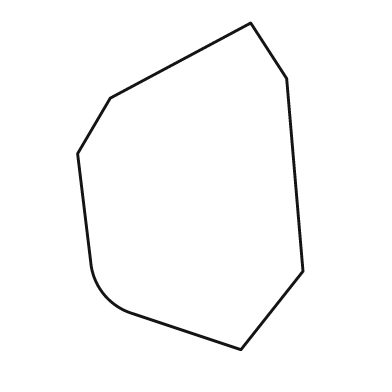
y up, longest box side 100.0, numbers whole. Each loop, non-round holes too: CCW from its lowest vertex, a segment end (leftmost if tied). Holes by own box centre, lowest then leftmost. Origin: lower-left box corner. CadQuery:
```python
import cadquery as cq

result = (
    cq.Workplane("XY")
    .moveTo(50.0, 0.0)
    .lineTo(69.0, 24.0)
    .lineTo(64.0, 83.0)
    .lineTo(53.0, 100.0)
    .lineTo(10.0, 77.0)
    .lineTo(0.0, 60.0)
    .lineTo(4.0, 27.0)
    .threePointArc((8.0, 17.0), (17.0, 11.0))
    .close()
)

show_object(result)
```